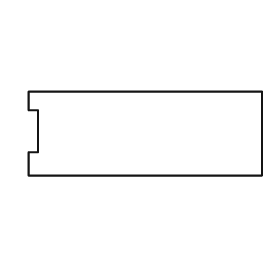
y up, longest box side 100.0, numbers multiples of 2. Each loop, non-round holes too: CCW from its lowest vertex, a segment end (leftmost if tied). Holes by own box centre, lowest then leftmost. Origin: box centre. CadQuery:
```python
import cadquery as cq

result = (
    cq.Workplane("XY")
    .moveTo(-50.0, -18.0)
    .lineTo(50.0, -18.0)
    .lineTo(50.0, 18.0)
    .lineTo(-50.0, 18.0)
    .lineTo(-50.0, 10.0)
    .lineTo(-46.0, 10.0)
    .lineTo(-46.0, -8.0)
    .lineTo(-50.0, -8.0)
    .close()
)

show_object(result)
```